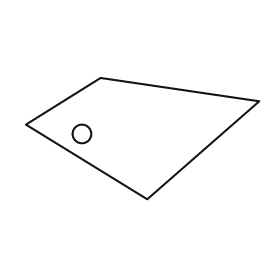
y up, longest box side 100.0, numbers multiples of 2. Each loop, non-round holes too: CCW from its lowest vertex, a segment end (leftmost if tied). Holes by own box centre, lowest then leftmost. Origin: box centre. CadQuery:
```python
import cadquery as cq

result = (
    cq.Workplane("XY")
    .moveTo(2.0, -26.0)
    .lineTo(50.0, 16.0)
    .lineTo(-18.0, 26.0)
    .lineTo(-50.0, 6.0)
    .close()
    .moveTo(-26.0, 2.0)
    .circle(4.0)
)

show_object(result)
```